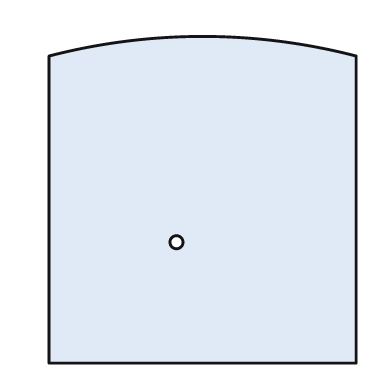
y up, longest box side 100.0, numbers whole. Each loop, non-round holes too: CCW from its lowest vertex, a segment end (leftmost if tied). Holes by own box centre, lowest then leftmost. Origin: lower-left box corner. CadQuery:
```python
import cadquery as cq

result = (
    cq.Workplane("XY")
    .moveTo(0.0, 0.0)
    .lineTo(94.0, 0.0)
    .lineTo(94.0, 94.0)
    .threePointArc((47.0, 100.0), (0.0, 94.0))
    .close()
    .moveTo(39.0, 37.0)
    .circle(2.0)
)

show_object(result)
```